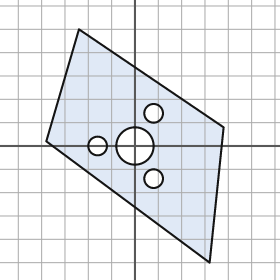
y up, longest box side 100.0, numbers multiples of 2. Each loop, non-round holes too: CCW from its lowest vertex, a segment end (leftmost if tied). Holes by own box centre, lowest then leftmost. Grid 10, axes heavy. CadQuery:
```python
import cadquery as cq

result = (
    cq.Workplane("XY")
    .moveTo(32.0, -50.0)
    .lineTo(38.0, 8.0)
    .lineTo(-24.0, 50.0)
    .lineTo(-38.0, 2.0)
    .close()
    .moveTo(8.0, -14.0)
    .circle(4.0)
    .moveTo(-16.0, 0.0)
    .circle(4.0)
    .moveTo(0.0, 0.0)
    .circle(8.0)
    .moveTo(8.0, 14.0)
    .circle(4.0)
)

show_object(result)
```